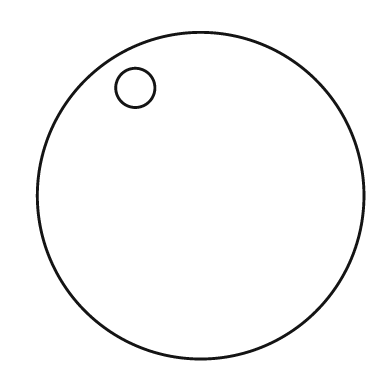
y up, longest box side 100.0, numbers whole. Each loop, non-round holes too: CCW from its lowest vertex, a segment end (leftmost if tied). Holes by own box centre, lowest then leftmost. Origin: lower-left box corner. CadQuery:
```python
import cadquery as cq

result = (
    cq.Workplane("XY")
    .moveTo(50.0, 50.0)
    .circle(50.0)
    .moveTo(30.0, 83.0)
    .circle(6.0)
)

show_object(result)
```